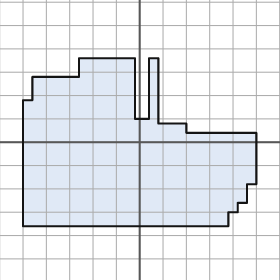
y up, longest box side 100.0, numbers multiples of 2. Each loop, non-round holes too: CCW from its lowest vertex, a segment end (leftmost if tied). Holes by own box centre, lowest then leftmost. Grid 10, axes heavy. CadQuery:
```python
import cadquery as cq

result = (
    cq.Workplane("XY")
    .moveTo(-50.0, -36.0)
    .lineTo(38.0, -36.0)
    .lineTo(38.0, -30.0)
    .lineTo(42.0, -30.0)
    .lineTo(42.0, -26.0)
    .lineTo(46.0, -26.0)
    .lineTo(46.0, -18.0)
    .lineTo(50.0, -18.0)
    .lineTo(50.0, 4.0)
    .lineTo(20.0, 4.0)
    .lineTo(20.0, 8.0)
    .lineTo(8.0, 8.0)
    .lineTo(8.0, 36.0)
    .lineTo(4.0, 36.0)
    .lineTo(4.0, 10.0)
    .lineTo(-2.0, 10.0)
    .lineTo(-2.0, 36.0)
    .lineTo(-26.0, 36.0)
    .lineTo(-26.0, 28.0)
    .lineTo(-46.0, 28.0)
    .lineTo(-46.0, 18.0)
    .lineTo(-50.0, 18.0)
    .close()
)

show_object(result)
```